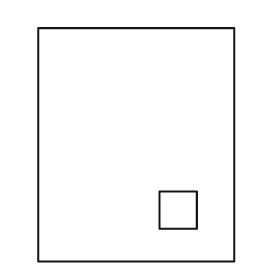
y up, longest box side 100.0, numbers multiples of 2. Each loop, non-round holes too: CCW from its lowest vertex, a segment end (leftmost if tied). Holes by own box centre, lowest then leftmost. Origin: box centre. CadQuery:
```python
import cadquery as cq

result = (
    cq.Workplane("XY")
    .moveTo(-42.0, -50.0)
    .lineTo(42.0, -50.0)
    .lineTo(42.0, 50.0)
    .lineTo(-42.0, 50.0)
    .close()
    .moveTo(10.0, -36.0)
    .lineTo(26.0, -36.0)
    .lineTo(26.0, -20.0)
    .lineTo(10.0, -20.0)
    .close()
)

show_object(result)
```